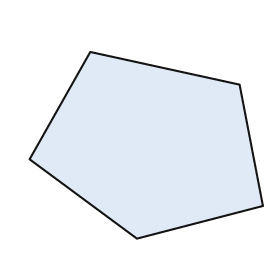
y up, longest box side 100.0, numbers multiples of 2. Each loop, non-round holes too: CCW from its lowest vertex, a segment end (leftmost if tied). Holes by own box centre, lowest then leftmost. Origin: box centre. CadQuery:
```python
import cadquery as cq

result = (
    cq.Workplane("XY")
    .moveTo(-4.0, -40.0)
    .lineTo(50.0, -26.0)
    .lineTo(40.0, 26.0)
    .lineTo(-24.0, 40.0)
    .lineTo(-50.0, -6.0)
    .close()
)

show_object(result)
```